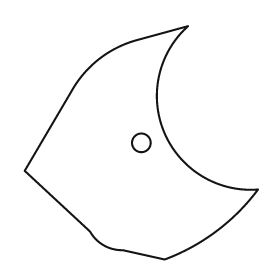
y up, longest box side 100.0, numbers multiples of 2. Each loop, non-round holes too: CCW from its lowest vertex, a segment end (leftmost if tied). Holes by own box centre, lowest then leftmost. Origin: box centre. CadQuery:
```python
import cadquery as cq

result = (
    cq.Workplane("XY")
    .moveTo(10.0, -50.0)
    .threePointArc((32.0, -38.0), (50.0, -20.0))
    .threePointArc((10.0, 4.0), (20.0, 50.0))
    .lineTo(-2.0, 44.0)
    .threePointArc((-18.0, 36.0), (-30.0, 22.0))
    .lineTo(-50.0, -12.0)
    .lineTo(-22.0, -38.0)
    .threePointArc((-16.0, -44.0), (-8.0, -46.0))
    .close()
    .moveTo(0.0, 0.0)
    .circle(4.0)
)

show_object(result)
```